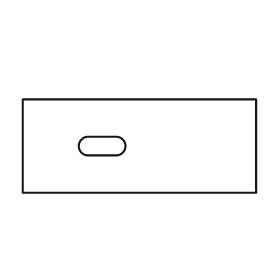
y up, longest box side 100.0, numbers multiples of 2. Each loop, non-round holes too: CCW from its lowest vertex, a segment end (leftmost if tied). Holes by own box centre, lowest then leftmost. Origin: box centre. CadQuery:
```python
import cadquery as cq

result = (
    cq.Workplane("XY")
    .moveTo(-50.0, -20.0)
    .lineTo(50.0, -20.0)
    .lineTo(50.0, 20.0)
    .lineTo(-50.0, 20.0)
    .close()
    .moveTo(-22.0, -4.0)
    .lineTo(-10.0, -4.0)
    .threePointArc((-6.0, 0.0), (-10.0, 4.0))
    .lineTo(-22.0, 4.0)
    .threePointArc((-26.0, 0.0), (-22.0, -4.0))
    .close()
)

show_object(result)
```